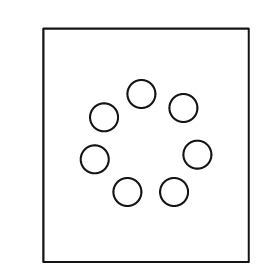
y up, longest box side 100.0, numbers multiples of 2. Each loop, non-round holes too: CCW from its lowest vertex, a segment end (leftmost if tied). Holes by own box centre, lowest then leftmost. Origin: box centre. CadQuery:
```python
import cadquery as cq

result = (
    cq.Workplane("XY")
    .moveTo(-44.0, -50.0)
    .lineTo(44.0, -50.0)
    .lineTo(44.0, 50.0)
    .lineTo(-44.0, 50.0)
    .close()
    .moveTo(-8.0, -20.0)
    .circle(6.0)
    .moveTo(12.0, -20.0)
    .circle(6.0)
    .moveTo(-22.0, -6.0)
    .circle(6.0)
    .moveTo(22.0, -4.0)
    .circle(6.0)
    .moveTo(-18.0, 12.0)
    .circle(6.0)
    .moveTo(16.0, 16.0)
    .circle(6.0)
    .moveTo(-2.0, 22.0)
    .circle(6.0)
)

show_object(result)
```